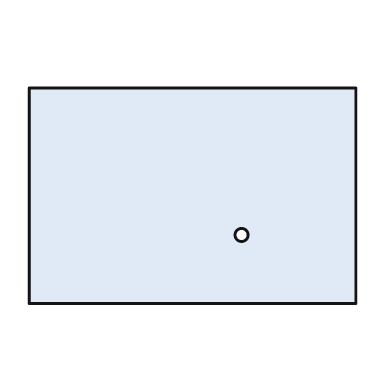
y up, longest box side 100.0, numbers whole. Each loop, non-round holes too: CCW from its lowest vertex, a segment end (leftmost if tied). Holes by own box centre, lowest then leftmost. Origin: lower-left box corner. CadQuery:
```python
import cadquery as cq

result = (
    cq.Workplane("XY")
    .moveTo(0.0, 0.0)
    .lineTo(100.0, 0.0)
    .lineTo(100.0, 66.0)
    .lineTo(0.0, 66.0)
    .close()
    .moveTo(65.0, 21.0)
    .circle(2.0)
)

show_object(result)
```